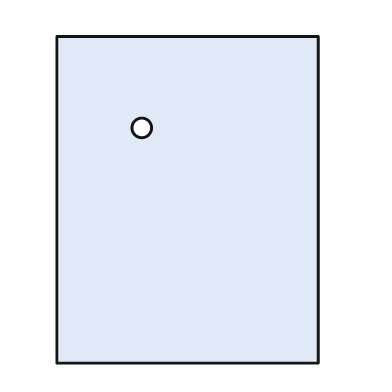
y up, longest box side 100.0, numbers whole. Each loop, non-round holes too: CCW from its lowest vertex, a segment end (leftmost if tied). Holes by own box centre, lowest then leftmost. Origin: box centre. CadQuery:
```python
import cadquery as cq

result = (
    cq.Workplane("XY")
    .moveTo(-40.0, -50.0)
    .lineTo(40.0, -50.0)
    .lineTo(40.0, 50.0)
    .lineTo(-40.0, 50.0)
    .close()
    .moveTo(-14.0, 22.0)
    .circle(3.0)
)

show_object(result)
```